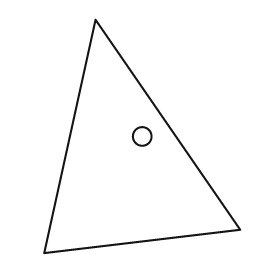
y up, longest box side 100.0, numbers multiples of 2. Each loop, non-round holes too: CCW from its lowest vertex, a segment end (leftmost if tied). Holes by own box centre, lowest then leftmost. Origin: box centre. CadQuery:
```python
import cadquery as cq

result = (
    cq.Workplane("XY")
    .moveTo(-42.0, -50.0)
    .lineTo(42.0, -40.0)
    .lineTo(-20.0, 50.0)
    .close()
    .moveTo(0.0, 0.0)
    .circle(4.0)
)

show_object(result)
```